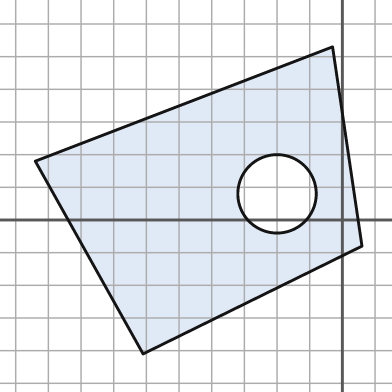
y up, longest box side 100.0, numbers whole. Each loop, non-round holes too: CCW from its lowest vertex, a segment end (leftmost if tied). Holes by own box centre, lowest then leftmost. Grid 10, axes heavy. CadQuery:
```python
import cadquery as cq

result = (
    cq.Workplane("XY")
    .moveTo(-61.0, -41.0)
    .lineTo(6.0, -8.0)
    .lineTo(-3.0, 53.0)
    .lineTo(-94.0, 18.0)
    .close()
    .moveTo(-20.0, 8.0)
    .circle(12.0)
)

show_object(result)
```